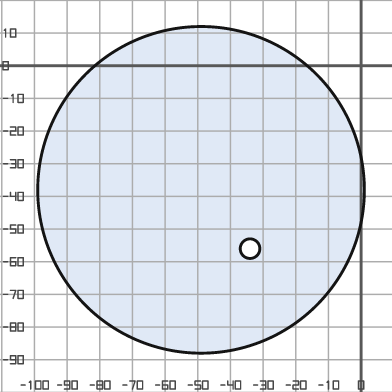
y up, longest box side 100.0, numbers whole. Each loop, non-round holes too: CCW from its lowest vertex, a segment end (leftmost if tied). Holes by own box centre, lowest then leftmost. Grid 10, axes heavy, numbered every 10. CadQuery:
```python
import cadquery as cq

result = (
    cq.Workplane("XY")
    .moveTo(-49.0, -38.0)
    .circle(50.0)
    .moveTo(-34.0, -56.0)
    .circle(3.0)
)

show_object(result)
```